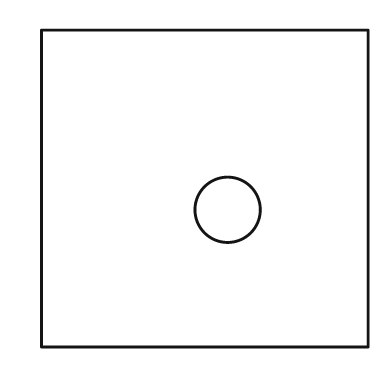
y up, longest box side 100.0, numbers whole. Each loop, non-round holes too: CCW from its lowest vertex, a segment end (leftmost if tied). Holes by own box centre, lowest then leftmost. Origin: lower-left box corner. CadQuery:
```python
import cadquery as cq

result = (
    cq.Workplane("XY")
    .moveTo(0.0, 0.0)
    .lineTo(100.0, 0.0)
    .lineTo(100.0, 97.0)
    .lineTo(0.0, 97.0)
    .close()
    .moveTo(57.0, 42.0)
    .circle(10.0)
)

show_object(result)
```